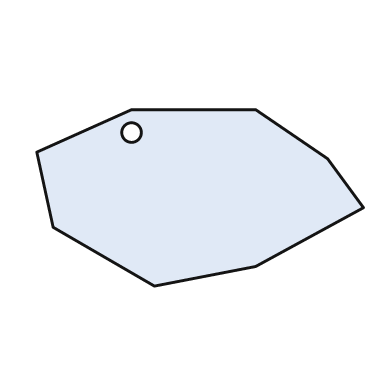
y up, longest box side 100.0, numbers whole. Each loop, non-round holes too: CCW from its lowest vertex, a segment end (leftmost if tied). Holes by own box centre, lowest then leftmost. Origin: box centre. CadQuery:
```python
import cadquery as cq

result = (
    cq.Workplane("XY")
    .moveTo(-14.0, -27.0)
    .lineTo(17.0, -21.0)
    .lineTo(50.0, -3.0)
    .lineTo(39.0, 12.0)
    .lineTo(17.0, 27.0)
    .lineTo(-21.0, 27.0)
    .lineTo(-50.0, 14.0)
    .lineTo(-45.0, -9.0)
    .close()
    .moveTo(-21.0, 20.0)
    .circle(3.0)
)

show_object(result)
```